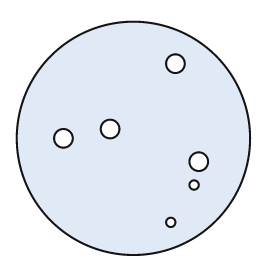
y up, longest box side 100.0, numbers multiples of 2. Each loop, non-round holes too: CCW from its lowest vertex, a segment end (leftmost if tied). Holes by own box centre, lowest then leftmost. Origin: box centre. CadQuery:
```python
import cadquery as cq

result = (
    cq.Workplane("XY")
    .moveTo(0.0, 0.0)
    .circle(50.0)
    .moveTo(16.0, -36.0)
    .circle(2.0)
    .moveTo(26.0, -20.0)
    .circle(2.0)
    .moveTo(28.0, -10.0)
    .circle(4.0)
    .moveTo(-30.0, 0.0)
    .circle(4.0)
    .moveTo(-10.0, 4.0)
    .circle(4.0)
    .moveTo(18.0, 32.0)
    .circle(4.0)
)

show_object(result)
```